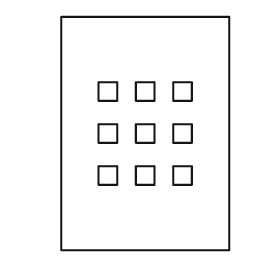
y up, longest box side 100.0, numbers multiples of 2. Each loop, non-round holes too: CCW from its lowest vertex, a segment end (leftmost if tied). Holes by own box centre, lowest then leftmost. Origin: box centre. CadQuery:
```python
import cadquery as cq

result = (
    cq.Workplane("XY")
    .moveTo(-36.0, -50.0)
    .lineTo(36.0, -50.0)
    .lineTo(36.0, 50.0)
    .lineTo(-36.0, 50.0)
    .close()
    .moveTo(-20.0, -22.0)
    .lineTo(-12.0, -22.0)
    .lineTo(-12.0, -14.0)
    .lineTo(-20.0, -14.0)
    .close()
    .moveTo(-4.0, -22.0)
    .lineTo(4.0, -22.0)
    .lineTo(4.0, -14.0)
    .lineTo(-4.0, -14.0)
    .close()
    .moveTo(12.0, -22.0)
    .lineTo(20.0, -22.0)
    .lineTo(20.0, -14.0)
    .lineTo(12.0, -14.0)
    .close()
    .moveTo(-20.0, -4.0)
    .lineTo(-12.0, -4.0)
    .lineTo(-12.0, 4.0)
    .lineTo(-20.0, 4.0)
    .close()
    .moveTo(-4.0, -4.0)
    .lineTo(4.0, -4.0)
    .lineTo(4.0, 4.0)
    .lineTo(-4.0, 4.0)
    .close()
    .moveTo(12.0, -4.0)
    .lineTo(20.0, -4.0)
    .lineTo(20.0, 4.0)
    .lineTo(12.0, 4.0)
    .close()
    .moveTo(-20.0, 14.0)
    .lineTo(-12.0, 14.0)
    .lineTo(-12.0, 22.0)
    .lineTo(-20.0, 22.0)
    .close()
    .moveTo(-4.0, 14.0)
    .lineTo(4.0, 14.0)
    .lineTo(4.0, 22.0)
    .lineTo(-4.0, 22.0)
    .close()
    .moveTo(12.0, 14.0)
    .lineTo(20.0, 14.0)
    .lineTo(20.0, 22.0)
    .lineTo(12.0, 22.0)
    .close()
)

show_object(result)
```